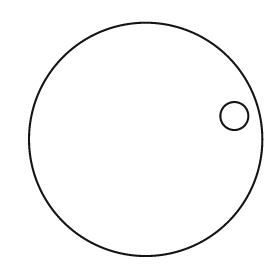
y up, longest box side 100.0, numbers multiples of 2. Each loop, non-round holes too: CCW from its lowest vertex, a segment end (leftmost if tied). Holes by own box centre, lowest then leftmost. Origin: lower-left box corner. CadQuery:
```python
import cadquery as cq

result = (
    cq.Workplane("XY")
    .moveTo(50.0, 50.0)
    .circle(50.0)
    .moveTo(88.0, 60.0)
    .circle(6.0)
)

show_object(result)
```